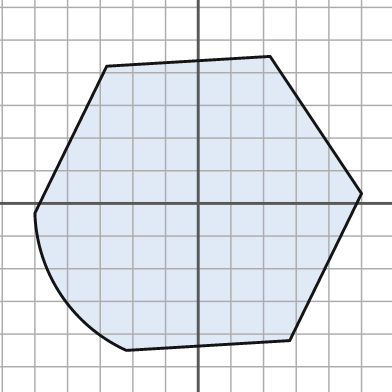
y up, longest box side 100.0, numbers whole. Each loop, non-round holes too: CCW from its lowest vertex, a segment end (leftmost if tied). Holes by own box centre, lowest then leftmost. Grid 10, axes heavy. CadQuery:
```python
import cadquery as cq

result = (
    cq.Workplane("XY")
    .moveTo(-22.0, -45.0)
    .lineTo(28.0, -42.0)
    .lineTo(50.0, 3.0)
    .lineTo(22.0, 45.0)
    .lineTo(-28.0, 42.0)
    .lineTo(-50.0, -3.0)
    .threePointArc((-42.0, -28.0), (-22.0, -45.0))
    .close()
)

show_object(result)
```